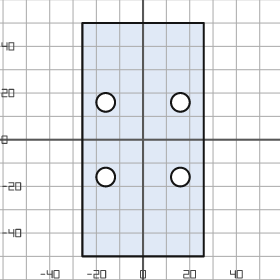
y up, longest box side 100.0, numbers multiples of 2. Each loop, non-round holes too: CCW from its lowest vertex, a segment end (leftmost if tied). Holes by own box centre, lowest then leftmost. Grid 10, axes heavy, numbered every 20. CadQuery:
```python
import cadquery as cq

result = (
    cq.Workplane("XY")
    .moveTo(-26.0, -50.0)
    .lineTo(26.0, -50.0)
    .lineTo(26.0, 50.0)
    .lineTo(-26.0, 50.0)
    .close()
    .moveTo(-16.0, -16.0)
    .circle(4.0)
    .moveTo(16.0, -16.0)
    .circle(4.0)
    .moveTo(-16.0, 16.0)
    .circle(4.0)
    .moveTo(16.0, 16.0)
    .circle(4.0)
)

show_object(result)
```